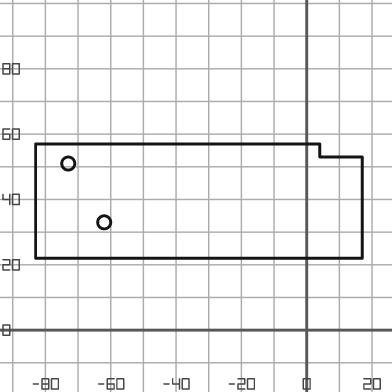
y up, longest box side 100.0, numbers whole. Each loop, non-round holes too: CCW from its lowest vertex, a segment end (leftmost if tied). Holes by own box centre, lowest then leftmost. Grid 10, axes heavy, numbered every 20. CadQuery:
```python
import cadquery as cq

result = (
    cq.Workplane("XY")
    .moveTo(-83.0, 22.0)
    .lineTo(17.0, 22.0)
    .lineTo(17.0, 53.0)
    .lineTo(4.0, 53.0)
    .lineTo(4.0, 57.0)
    .lineTo(-83.0, 57.0)
    .close()
    .moveTo(-62.0, 33.0)
    .circle(2.0)
    .moveTo(-73.0, 51.0)
    .circle(2.0)
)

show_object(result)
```